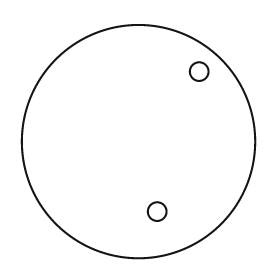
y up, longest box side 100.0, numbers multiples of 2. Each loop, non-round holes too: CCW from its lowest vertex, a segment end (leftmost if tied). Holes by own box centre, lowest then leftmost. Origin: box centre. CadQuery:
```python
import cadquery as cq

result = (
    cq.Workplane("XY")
    .moveTo(0.0, 0.0)
    .circle(50.0)
    .moveTo(8.0, -30.0)
    .circle(4.0)
    .moveTo(26.0, 30.0)
    .circle(4.0)
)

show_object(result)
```